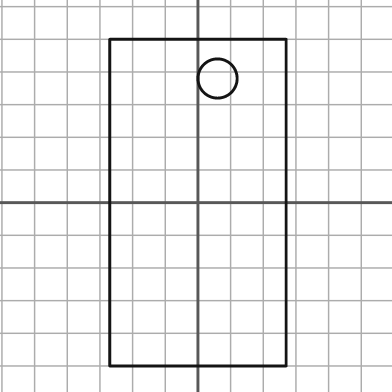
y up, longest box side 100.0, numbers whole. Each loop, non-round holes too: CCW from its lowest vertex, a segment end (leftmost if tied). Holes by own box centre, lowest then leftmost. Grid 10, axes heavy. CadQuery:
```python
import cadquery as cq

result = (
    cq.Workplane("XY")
    .moveTo(-27.0, -50.0)
    .lineTo(27.0, -50.0)
    .lineTo(27.0, 50.0)
    .lineTo(-27.0, 50.0)
    .close()
    .moveTo(6.0, 38.0)
    .circle(6.0)
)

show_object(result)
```